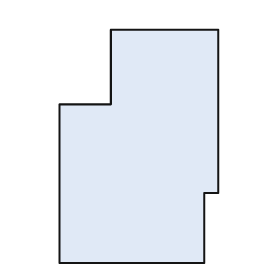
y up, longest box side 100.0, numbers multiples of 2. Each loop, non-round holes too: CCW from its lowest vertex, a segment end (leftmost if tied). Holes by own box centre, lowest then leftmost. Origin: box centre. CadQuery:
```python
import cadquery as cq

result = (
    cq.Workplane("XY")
    .moveTo(-34.0, -50.0)
    .lineTo(28.0, -50.0)
    .lineTo(28.0, -20.0)
    .lineTo(34.0, -20.0)
    .lineTo(34.0, 50.0)
    .lineTo(-12.0, 50.0)
    .lineTo(-12.0, 18.0)
    .lineTo(-34.0, 18.0)
    .close()
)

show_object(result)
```